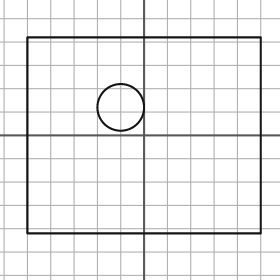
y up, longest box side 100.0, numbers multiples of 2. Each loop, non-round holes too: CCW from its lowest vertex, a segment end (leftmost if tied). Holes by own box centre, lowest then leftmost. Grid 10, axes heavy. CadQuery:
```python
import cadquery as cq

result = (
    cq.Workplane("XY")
    .moveTo(-50.0, -42.0)
    .lineTo(50.0, -42.0)
    .lineTo(50.0, 42.0)
    .lineTo(-50.0, 42.0)
    .close()
    .moveTo(-10.0, 12.0)
    .circle(10.0)
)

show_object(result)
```